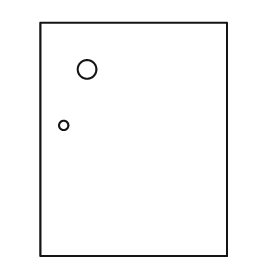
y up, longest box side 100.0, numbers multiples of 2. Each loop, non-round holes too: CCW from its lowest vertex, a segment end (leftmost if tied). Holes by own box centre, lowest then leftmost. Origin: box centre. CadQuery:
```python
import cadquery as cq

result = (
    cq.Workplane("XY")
    .moveTo(-40.0, -50.0)
    .lineTo(40.0, -50.0)
    .lineTo(40.0, 50.0)
    .lineTo(-40.0, 50.0)
    .close()
    .moveTo(-30.0, 6.0)
    .circle(2.0)
    .moveTo(-20.0, 30.0)
    .circle(4.0)
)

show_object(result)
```